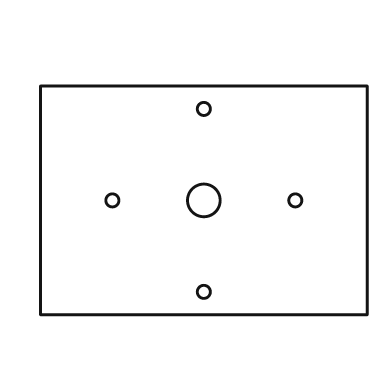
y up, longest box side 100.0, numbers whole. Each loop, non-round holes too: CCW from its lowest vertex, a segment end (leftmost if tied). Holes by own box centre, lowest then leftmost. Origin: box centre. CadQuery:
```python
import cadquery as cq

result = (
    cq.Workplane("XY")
    .moveTo(-50.0, -35.0)
    .lineTo(50.0, -35.0)
    .lineTo(50.0, 35.0)
    .lineTo(-50.0, 35.0)
    .close()
    .moveTo(0.0, -28.0)
    .circle(2.0)
    .moveTo(-28.0, 0.0)
    .circle(2.0)
    .moveTo(0.0, 0.0)
    .circle(5.0)
    .moveTo(28.0, 0.0)
    .circle(2.0)
    .moveTo(0.0, 28.0)
    .circle(2.0)
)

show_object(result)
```